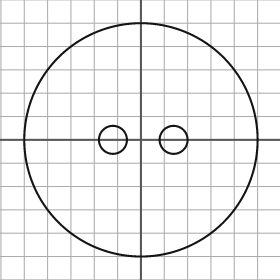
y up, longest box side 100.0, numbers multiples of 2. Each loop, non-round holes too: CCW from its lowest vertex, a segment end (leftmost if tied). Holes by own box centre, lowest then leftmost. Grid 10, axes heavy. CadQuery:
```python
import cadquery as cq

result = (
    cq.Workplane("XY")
    .moveTo(0.0, 0.0)
    .circle(50.0)
    .moveTo(-12.0, 0.0)
    .circle(6.0)
    .moveTo(14.0, 0.0)
    .circle(6.0)
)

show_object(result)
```